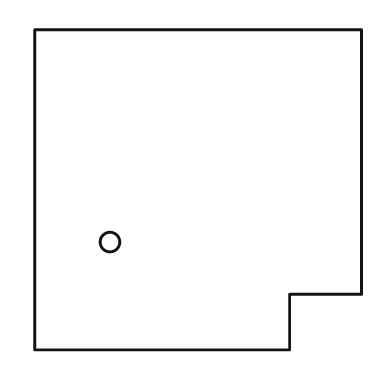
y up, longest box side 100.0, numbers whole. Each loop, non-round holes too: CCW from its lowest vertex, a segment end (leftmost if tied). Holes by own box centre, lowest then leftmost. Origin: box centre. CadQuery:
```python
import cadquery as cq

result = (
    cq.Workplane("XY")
    .moveTo(-50.0, -49.0)
    .lineTo(28.0, -49.0)
    .lineTo(28.0, -32.0)
    .lineTo(50.0, -32.0)
    .lineTo(50.0, 49.0)
    .lineTo(-50.0, 49.0)
    .close()
    .moveTo(-27.0, -16.0)
    .circle(3.0)
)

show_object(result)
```